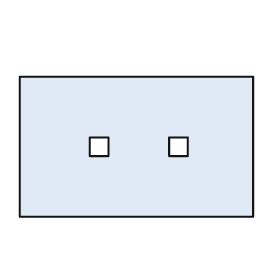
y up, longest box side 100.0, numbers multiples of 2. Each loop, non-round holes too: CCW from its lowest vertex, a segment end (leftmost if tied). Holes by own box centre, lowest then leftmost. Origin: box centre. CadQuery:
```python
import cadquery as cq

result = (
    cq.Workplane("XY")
    .moveTo(-50.0, -30.0)
    .lineTo(50.0, -30.0)
    .lineTo(50.0, 30.0)
    .lineTo(-50.0, 30.0)
    .close()
    .moveTo(-20.0, -4.0)
    .lineTo(-12.0, -4.0)
    .lineTo(-12.0, 4.0)
    .lineTo(-20.0, 4.0)
    .close()
    .moveTo(14.0, -4.0)
    .lineTo(22.0, -4.0)
    .lineTo(22.0, 4.0)
    .lineTo(14.0, 4.0)
    .close()
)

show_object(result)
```